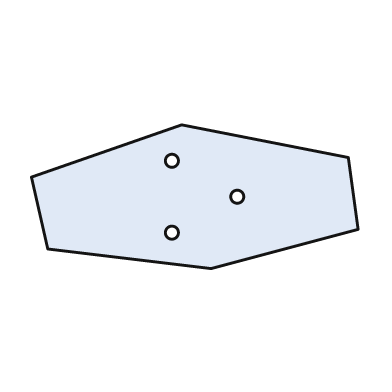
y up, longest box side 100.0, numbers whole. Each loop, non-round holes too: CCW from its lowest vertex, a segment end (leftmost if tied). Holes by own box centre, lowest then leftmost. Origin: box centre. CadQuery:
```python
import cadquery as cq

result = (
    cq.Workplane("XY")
    .moveTo(5.0, -22.0)
    .lineTo(50.0, -10.0)
    .lineTo(47.0, 12.0)
    .lineTo(-4.0, 22.0)
    .lineTo(-50.0, 6.0)
    .lineTo(-45.0, -16.0)
    .close()
    .moveTo(-7.0, -11.0)
    .circle(2.0)
    .moveTo(13.0, 0.0)
    .circle(2.0)
    .moveTo(-7.0, 11.0)
    .circle(2.0)
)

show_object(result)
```